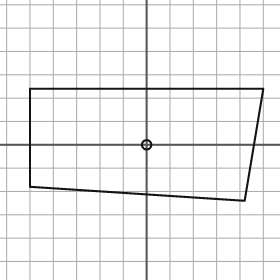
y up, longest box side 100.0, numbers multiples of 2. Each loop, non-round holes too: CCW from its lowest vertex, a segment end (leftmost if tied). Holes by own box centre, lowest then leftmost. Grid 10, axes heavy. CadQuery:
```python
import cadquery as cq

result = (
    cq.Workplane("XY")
    .moveTo(42.0, -24.0)
    .lineTo(50.0, 24.0)
    .lineTo(-50.0, 24.0)
    .lineTo(-50.0, -18.0)
    .close()
    .moveTo(0.0, 0.0)
    .circle(2.0)
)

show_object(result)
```